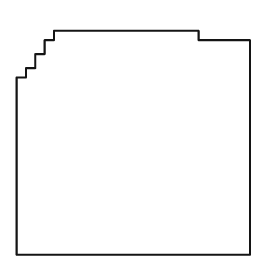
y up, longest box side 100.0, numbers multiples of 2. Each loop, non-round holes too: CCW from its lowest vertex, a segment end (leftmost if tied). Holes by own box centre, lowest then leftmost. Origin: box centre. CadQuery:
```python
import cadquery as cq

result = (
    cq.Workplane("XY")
    .moveTo(-50.0, -48.0)
    .lineTo(50.0, -48.0)
    .lineTo(50.0, 44.0)
    .lineTo(28.0, 44.0)
    .lineTo(28.0, 48.0)
    .lineTo(-34.0, 48.0)
    .lineTo(-34.0, 44.0)
    .lineTo(-38.0, 44.0)
    .lineTo(-38.0, 38.0)
    .lineTo(-42.0, 38.0)
    .lineTo(-42.0, 32.0)
    .lineTo(-46.0, 32.0)
    .lineTo(-46.0, 28.0)
    .lineTo(-50.0, 28.0)
    .close()
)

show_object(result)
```